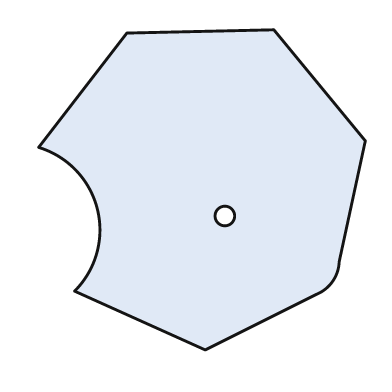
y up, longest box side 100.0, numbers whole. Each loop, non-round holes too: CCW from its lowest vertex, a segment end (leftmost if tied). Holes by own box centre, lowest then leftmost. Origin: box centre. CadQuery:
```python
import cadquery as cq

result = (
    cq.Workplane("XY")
    .moveTo(1.0, -49.0)
    .lineTo(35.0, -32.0)
    .threePointArc((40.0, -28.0), (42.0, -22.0))
    .lineTo(50.0, 15.0)
    .lineTo(22.0, 49.0)
    .lineTo(-23.0, 48.0)
    .lineTo(-50.0, 13.0)
    .threePointArc((-32.0, -6.0), (-39.0, -31.0))
    .close()
    .moveTo(7.0, -8.0)
    .circle(3.0)
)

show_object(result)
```